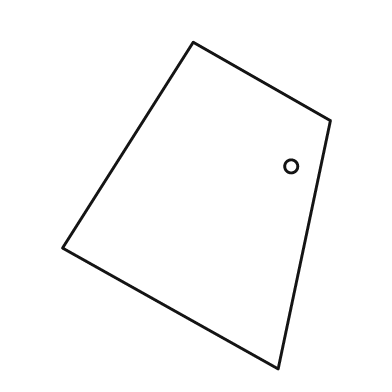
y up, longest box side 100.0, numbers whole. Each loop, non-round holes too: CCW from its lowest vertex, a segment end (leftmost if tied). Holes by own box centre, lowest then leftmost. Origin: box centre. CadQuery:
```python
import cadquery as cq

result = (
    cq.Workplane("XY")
    .moveTo(25.0, -50.0)
    .lineTo(41.0, 26.0)
    .lineTo(-1.0, 50.0)
    .lineTo(-41.0, -13.0)
    .close()
    .moveTo(29.0, 12.0)
    .circle(2.0)
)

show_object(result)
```